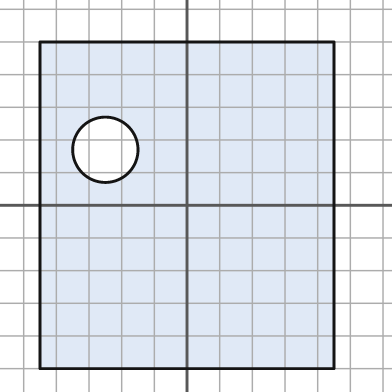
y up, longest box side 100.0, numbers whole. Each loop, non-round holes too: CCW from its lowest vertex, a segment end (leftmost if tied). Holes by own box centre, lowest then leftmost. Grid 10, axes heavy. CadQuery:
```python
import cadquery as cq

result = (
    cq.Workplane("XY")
    .moveTo(-45.0, -50.0)
    .lineTo(45.0, -50.0)
    .lineTo(45.0, 50.0)
    .lineTo(-45.0, 50.0)
    .close()
    .moveTo(-25.0, 17.0)
    .circle(10.0)
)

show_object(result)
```